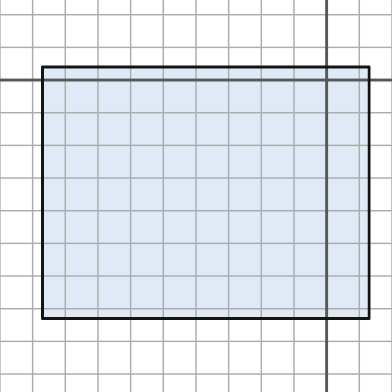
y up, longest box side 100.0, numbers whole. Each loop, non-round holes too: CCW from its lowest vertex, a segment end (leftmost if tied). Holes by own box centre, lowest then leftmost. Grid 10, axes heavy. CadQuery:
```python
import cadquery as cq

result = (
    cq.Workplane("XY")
    .moveTo(-87.0, -73.0)
    .lineTo(13.0, -73.0)
    .lineTo(13.0, 4.0)
    .lineTo(-87.0, 4.0)
    .close()
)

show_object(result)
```